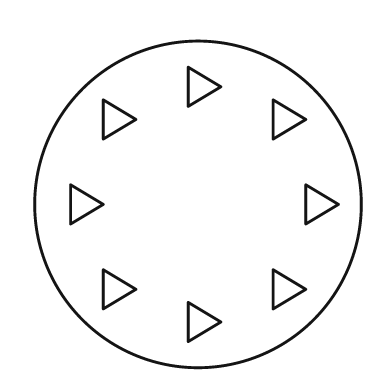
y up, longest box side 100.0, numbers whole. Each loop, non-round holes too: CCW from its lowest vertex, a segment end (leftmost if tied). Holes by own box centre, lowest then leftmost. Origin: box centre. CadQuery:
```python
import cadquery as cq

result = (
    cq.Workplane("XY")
    .moveTo(0.0, 0.0)
    .circle(50.0)
    .moveTo(-3.0, -42.0)
    .lineTo(7.0, -36.0)
    .lineTo(-3.0, -30.0)
    .close()
    .moveTo(-29.0, -32.0)
    .lineTo(-19.0, -26.0)
    .lineTo(-29.0, -20.0)
    .close()
    .moveTo(23.0, -32.0)
    .lineTo(33.0, -26.0)
    .lineTo(23.0, -20.0)
    .close()
    .moveTo(-39.0, -6.0)
    .lineTo(-29.0, 0.0)
    .lineTo(-39.0, 6.0)
    .close()
    .moveTo(33.0, -6.0)
    .lineTo(43.0, 0.0)
    .lineTo(33.0, 6.0)
    .close()
    .moveTo(-29.0, 20.0)
    .lineTo(-19.0, 26.0)
    .lineTo(-29.0, 32.0)
    .close()
    .moveTo(23.0, 20.0)
    .lineTo(33.0, 26.0)
    .lineTo(23.0, 32.0)
    .close()
    .moveTo(-3.0, 30.0)
    .lineTo(7.0, 36.0)
    .lineTo(-3.0, 42.0)
    .close()
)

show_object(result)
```